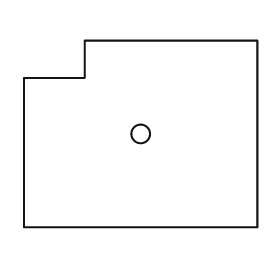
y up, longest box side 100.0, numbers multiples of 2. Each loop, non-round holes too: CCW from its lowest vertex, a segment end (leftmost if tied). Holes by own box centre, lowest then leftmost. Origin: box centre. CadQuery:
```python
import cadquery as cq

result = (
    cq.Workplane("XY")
    .moveTo(-50.0, -40.0)
    .lineTo(50.0, -40.0)
    .lineTo(50.0, 40.0)
    .lineTo(-24.0, 40.0)
    .lineTo(-24.0, 24.0)
    .lineTo(-50.0, 24.0)
    .close()
    .moveTo(0.0, 0.0)
    .circle(4.0)
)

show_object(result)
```